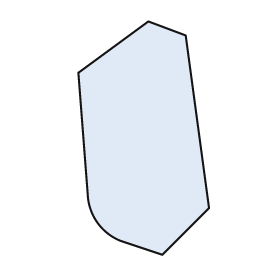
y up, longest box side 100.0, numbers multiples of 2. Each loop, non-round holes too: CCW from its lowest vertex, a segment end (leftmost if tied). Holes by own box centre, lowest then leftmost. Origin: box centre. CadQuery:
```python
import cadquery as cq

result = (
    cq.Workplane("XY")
    .moveTo(8.0, -50.0)
    .lineTo(28.0, -30.0)
    .lineTo(18.0, 44.0)
    .lineTo(2.0, 50.0)
    .lineTo(-28.0, 28.0)
    .lineTo(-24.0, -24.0)
    .threePointArc((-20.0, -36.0), (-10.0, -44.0))
    .close()
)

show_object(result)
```